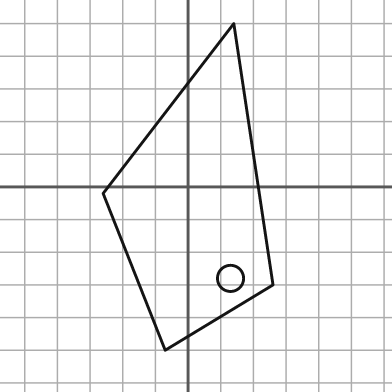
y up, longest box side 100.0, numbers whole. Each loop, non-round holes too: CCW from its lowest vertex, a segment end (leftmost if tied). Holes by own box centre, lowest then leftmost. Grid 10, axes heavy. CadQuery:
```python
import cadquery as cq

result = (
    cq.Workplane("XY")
    .moveTo(-7.0, -50.0)
    .lineTo(26.0, -30.0)
    .lineTo(14.0, 50.0)
    .lineTo(-26.0, -2.0)
    .close()
    .moveTo(13.0, -28.0)
    .circle(4.0)
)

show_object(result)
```